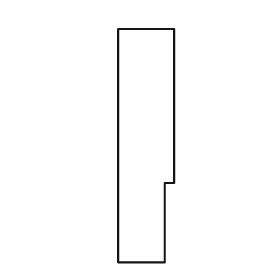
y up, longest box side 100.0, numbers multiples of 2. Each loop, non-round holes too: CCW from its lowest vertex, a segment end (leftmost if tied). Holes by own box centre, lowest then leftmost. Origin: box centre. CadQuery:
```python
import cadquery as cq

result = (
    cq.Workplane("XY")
    .moveTo(-12.0, -50.0)
    .lineTo(8.0, -50.0)
    .lineTo(8.0, -16.0)
    .lineTo(12.0, -16.0)
    .lineTo(12.0, 50.0)
    .lineTo(-12.0, 50.0)
    .close()
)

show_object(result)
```